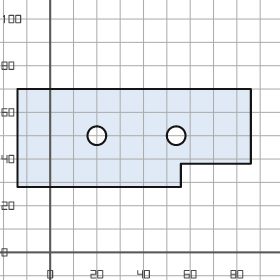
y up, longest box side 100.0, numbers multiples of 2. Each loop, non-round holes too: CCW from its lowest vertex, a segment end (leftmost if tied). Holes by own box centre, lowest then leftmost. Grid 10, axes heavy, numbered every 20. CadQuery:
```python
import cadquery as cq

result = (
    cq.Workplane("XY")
    .moveTo(-14.0, 28.0)
    .lineTo(56.0, 28.0)
    .lineTo(56.0, 38.0)
    .lineTo(86.0, 38.0)
    .lineTo(86.0, 70.0)
    .lineTo(-14.0, 70.0)
    .close()
    .moveTo(20.0, 50.0)
    .circle(4.0)
    .moveTo(54.0, 50.0)
    .circle(4.0)
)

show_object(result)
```